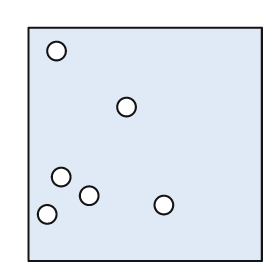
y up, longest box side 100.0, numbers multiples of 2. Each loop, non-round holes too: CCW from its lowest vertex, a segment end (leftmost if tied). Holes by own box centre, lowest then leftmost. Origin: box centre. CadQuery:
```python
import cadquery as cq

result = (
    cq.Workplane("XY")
    .moveTo(-50.0, -50.0)
    .lineTo(50.0, -50.0)
    .lineTo(50.0, 50.0)
    .lineTo(-50.0, 50.0)
    .close()
    .moveTo(-42.0, -30.0)
    .circle(4.0)
    .moveTo(8.0, -26.0)
    .circle(4.0)
    .moveTo(-24.0, -22.0)
    .circle(4.0)
    .moveTo(-36.0, -14.0)
    .circle(4.0)
    .moveTo(-8.0, 16.0)
    .circle(4.0)
    .moveTo(-38.0, 40.0)
    .circle(4.0)
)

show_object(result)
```